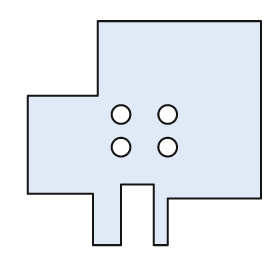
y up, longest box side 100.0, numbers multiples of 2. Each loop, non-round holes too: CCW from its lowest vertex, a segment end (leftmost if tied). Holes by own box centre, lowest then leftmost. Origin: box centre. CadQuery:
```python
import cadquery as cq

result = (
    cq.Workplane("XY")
    .moveTo(-22.0, -48.0)
    .lineTo(-10.0, -48.0)
    .lineTo(-10.0, -22.0)
    .lineTo(4.0, -22.0)
    .lineTo(4.0, -48.0)
    .lineTo(10.0, -48.0)
    .lineTo(10.0, -28.0)
    .lineTo(50.0, -28.0)
    .lineTo(50.0, 48.0)
    .lineTo(-20.0, 48.0)
    .lineTo(-20.0, 16.0)
    .lineTo(-50.0, 16.0)
    .lineTo(-50.0, -26.0)
    .lineTo(-22.0, -26.0)
    .close()
    .moveTo(-10.0, -6.0)
    .circle(4.0)
    .moveTo(10.0, -6.0)
    .circle(4.0)
    .moveTo(-10.0, 8.0)
    .circle(4.0)
    .moveTo(10.0, 8.0)
    .circle(4.0)
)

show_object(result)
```